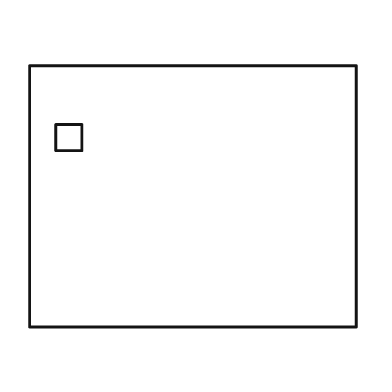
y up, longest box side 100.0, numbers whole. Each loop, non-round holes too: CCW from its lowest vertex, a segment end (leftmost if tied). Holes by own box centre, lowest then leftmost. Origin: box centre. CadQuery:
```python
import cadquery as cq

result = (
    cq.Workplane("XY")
    .moveTo(-50.0, -40.0)
    .lineTo(50.0, -40.0)
    .lineTo(50.0, 40.0)
    .lineTo(-50.0, 40.0)
    .close()
    .moveTo(-42.0, 14.0)
    .lineTo(-34.0, 14.0)
    .lineTo(-34.0, 22.0)
    .lineTo(-42.0, 22.0)
    .close()
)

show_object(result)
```